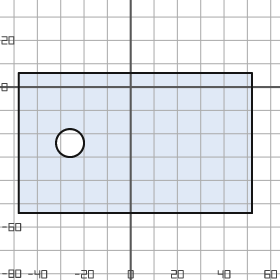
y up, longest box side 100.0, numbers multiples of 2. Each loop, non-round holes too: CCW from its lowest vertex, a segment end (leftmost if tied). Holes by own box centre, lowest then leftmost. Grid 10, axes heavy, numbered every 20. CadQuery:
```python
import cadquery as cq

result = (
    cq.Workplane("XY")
    .moveTo(-48.0, -54.0)
    .lineTo(52.0, -54.0)
    .lineTo(52.0, 6.0)
    .lineTo(-48.0, 6.0)
    .close()
    .moveTo(-26.0, -24.0)
    .circle(6.0)
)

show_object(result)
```